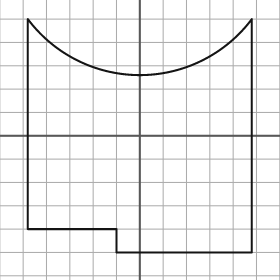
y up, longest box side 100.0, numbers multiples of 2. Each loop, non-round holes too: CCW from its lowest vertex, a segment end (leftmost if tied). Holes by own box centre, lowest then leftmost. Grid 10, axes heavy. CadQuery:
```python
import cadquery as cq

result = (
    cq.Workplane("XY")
    .moveTo(-10.0, -50.0)
    .lineTo(48.0, -50.0)
    .lineTo(48.0, 50.0)
    .threePointArc((0.0, 26.0), (-48.0, 50.0))
    .lineTo(-48.0, -40.0)
    .lineTo(-10.0, -40.0)
    .close()
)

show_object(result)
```